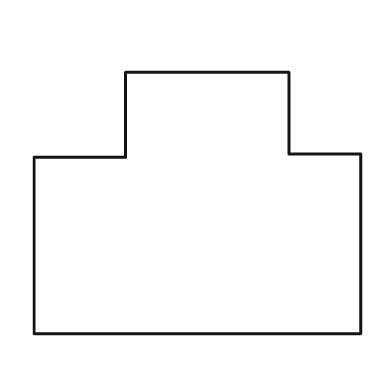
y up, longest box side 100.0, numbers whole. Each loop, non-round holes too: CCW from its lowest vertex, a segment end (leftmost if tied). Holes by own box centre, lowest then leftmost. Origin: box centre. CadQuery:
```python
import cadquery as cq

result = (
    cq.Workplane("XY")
    .moveTo(-50.0, -40.0)
    .lineTo(50.0, -40.0)
    .lineTo(50.0, 15.0)
    .lineTo(28.0, 15.0)
    .lineTo(28.0, 40.0)
    .lineTo(-22.0, 40.0)
    .lineTo(-22.0, 14.0)
    .lineTo(-50.0, 14.0)
    .close()
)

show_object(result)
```